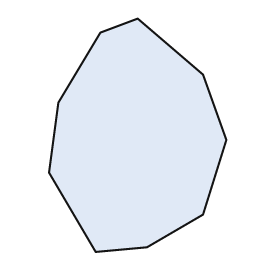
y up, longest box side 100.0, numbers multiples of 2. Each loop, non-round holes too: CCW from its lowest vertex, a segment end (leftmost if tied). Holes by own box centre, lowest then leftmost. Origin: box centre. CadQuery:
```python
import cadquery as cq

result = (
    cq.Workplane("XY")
    .moveTo(-18.0, -50.0)
    .lineTo(4.0, -48.0)
    .lineTo(28.0, -34.0)
    .lineTo(38.0, -2.0)
    .lineTo(28.0, 26.0)
    .lineTo(0.0, 50.0)
    .lineTo(-16.0, 44.0)
    .lineTo(-34.0, 14.0)
    .lineTo(-38.0, -16.0)
    .close()
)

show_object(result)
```